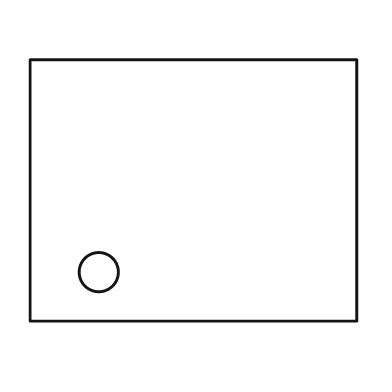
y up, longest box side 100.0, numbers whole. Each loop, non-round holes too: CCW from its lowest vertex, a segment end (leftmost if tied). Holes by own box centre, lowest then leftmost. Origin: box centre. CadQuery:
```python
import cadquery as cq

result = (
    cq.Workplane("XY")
    .moveTo(-50.0, -40.0)
    .lineTo(50.0, -40.0)
    .lineTo(50.0, 40.0)
    .lineTo(-50.0, 40.0)
    .close()
    .moveTo(-29.0, -25.0)
    .circle(6.0)
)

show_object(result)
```